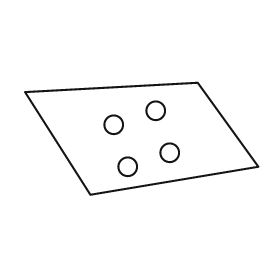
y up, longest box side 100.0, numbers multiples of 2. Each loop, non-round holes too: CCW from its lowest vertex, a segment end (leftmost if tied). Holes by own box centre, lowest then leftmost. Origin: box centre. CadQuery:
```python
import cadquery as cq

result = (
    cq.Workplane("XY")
    .moveTo(-22.0, -24.0)
    .lineTo(50.0, -12.0)
    .lineTo(24.0, 24.0)
    .lineTo(-50.0, 20.0)
    .close()
    .moveTo(-6.0, -12.0)
    .circle(4.0)
    .moveTo(12.0, -6.0)
    .circle(4.0)
    .moveTo(-12.0, 6.0)
    .circle(4.0)
    .moveTo(6.0, 12.0)
    .circle(4.0)
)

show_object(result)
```